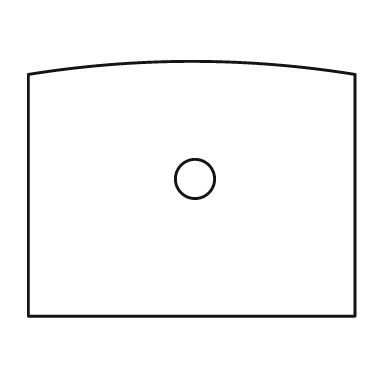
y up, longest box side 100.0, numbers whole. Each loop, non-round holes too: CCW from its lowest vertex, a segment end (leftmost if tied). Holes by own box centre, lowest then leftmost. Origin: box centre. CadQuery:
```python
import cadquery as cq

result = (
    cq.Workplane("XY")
    .moveTo(-50.0, -39.0)
    .lineTo(50.0, -39.0)
    .lineTo(50.0, 35.0)
    .threePointArc((0.0, 39.0), (-50.0, 35.0))
    .close()
    .moveTo(1.0, 3.0)
    .circle(6.0)
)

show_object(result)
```